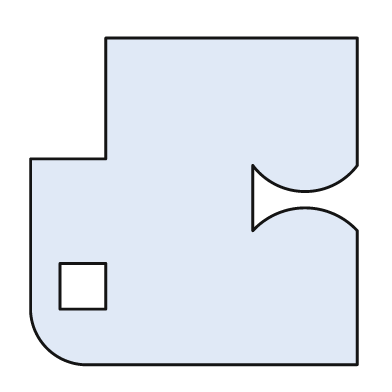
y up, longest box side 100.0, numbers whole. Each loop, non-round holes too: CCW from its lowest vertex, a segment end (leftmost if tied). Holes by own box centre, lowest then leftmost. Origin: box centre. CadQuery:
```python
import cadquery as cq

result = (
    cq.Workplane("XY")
    .moveTo(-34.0, -50.0)
    .lineTo(50.0, -50.0)
    .lineTo(50.0, -9.0)
    .threePointArc((34.0, -2.0), (18.0, -9.0))
    .lineTo(18.0, 11.0)
    .threePointArc((34.0, 3.0), (50.0, 11.0))
    .lineTo(50.0, 50.0)
    .lineTo(-27.0, 50.0)
    .lineTo(-27.0, 13.0)
    .lineTo(-50.0, 13.0)
    .lineTo(-50.0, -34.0)
    .threePointArc((-45.0, -45.0), (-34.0, -50.0))
    .close()
    .moveTo(-41.0, -33.0)
    .lineTo(-27.0, -33.0)
    .lineTo(-27.0, -19.0)
    .lineTo(-41.0, -19.0)
    .close()
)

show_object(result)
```